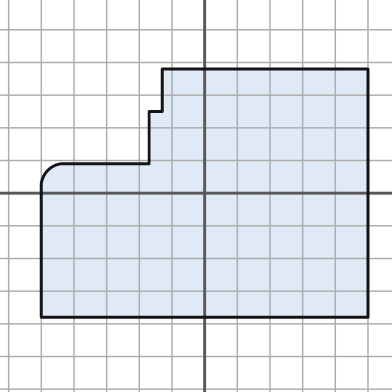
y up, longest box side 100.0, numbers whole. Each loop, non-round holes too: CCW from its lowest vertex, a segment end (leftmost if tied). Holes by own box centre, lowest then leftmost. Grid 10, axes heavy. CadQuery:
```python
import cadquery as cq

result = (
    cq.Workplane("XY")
    .moveTo(-50.0, -38.0)
    .lineTo(50.0, -38.0)
    .lineTo(50.0, 38.0)
    .lineTo(-13.0, 38.0)
    .lineTo(-13.0, 25.0)
    .lineTo(-17.0, 25.0)
    .lineTo(-17.0, 9.0)
    .lineTo(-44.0, 9.0)
    .threePointArc((-48.0, 7.0), (-50.0, 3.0))
    .close()
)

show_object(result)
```